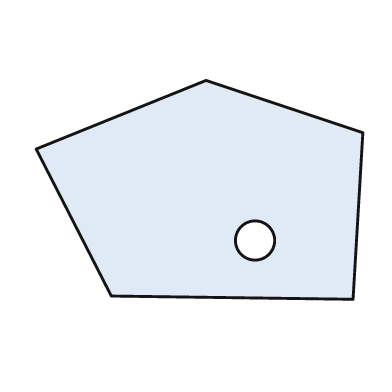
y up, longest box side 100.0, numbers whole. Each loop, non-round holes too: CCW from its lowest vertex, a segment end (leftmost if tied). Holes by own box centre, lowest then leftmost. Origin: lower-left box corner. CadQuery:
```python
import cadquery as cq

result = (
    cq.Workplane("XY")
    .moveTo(97.0, 0.0)
    .lineTo(100.0, 51.0)
    .lineTo(52.0, 67.0)
    .lineTo(0.0, 46.0)
    .lineTo(23.0, 1.0)
    .close()
    .moveTo(67.0, 18.0)
    .circle(6.0)
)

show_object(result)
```